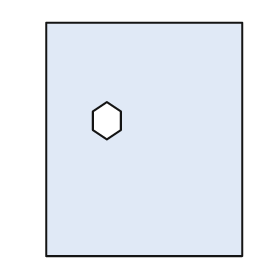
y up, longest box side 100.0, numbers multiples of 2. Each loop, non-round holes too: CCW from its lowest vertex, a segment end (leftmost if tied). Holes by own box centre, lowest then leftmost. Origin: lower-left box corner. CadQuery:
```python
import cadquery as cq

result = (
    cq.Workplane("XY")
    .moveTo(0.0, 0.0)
    .lineTo(84.0, 0.0)
    .lineTo(84.0, 100.0)
    .lineTo(0.0, 100.0)
    .close()
    .moveTo(26.0, 50.0)
    .lineTo(32.0, 54.0)
    .lineTo(32.0, 62.0)
    .lineTo(26.0, 66.0)
    .lineTo(20.0, 62.0)
    .lineTo(20.0, 54.0)
    .close()
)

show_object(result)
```